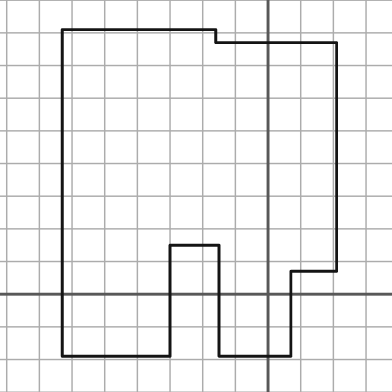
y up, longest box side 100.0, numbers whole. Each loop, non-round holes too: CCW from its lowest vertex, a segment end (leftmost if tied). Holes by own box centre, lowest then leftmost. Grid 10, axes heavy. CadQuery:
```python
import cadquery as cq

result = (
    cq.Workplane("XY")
    .moveTo(-63.0, -19.0)
    .lineTo(-30.0, -19.0)
    .lineTo(-30.0, 15.0)
    .lineTo(-15.0, 15.0)
    .lineTo(-15.0, -19.0)
    .lineTo(7.0, -19.0)
    .lineTo(7.0, 7.0)
    .lineTo(21.0, 7.0)
    .lineTo(21.0, 77.0)
    .lineTo(-16.0, 77.0)
    .lineTo(-16.0, 81.0)
    .lineTo(-63.0, 81.0)
    .close()
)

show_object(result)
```